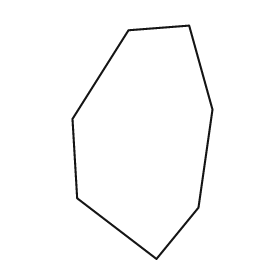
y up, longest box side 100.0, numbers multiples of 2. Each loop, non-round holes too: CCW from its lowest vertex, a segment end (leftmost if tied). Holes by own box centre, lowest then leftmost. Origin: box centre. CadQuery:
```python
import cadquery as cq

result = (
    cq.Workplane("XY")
    .moveTo(6.0, -50.0)
    .lineTo(24.0, -28.0)
    .lineTo(30.0, 14.0)
    .lineTo(20.0, 50.0)
    .lineTo(-6.0, 48.0)
    .lineTo(-30.0, 10.0)
    .lineTo(-28.0, -24.0)
    .close()
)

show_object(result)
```